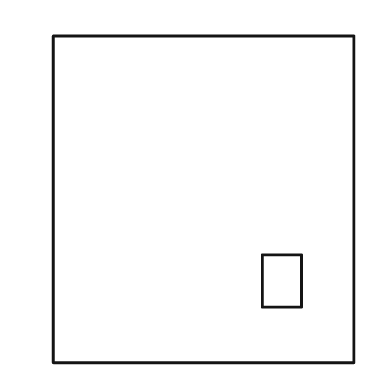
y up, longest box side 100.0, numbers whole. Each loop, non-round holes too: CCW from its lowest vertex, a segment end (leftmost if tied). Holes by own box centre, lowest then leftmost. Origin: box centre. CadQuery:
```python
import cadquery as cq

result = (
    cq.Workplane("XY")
    .moveTo(-46.0, -50.0)
    .lineTo(46.0, -50.0)
    .lineTo(46.0, 50.0)
    .lineTo(-46.0, 50.0)
    .close()
    .moveTo(18.0, -33.0)
    .lineTo(30.0, -33.0)
    .lineTo(30.0, -17.0)
    .lineTo(18.0, -17.0)
    .close()
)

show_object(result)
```